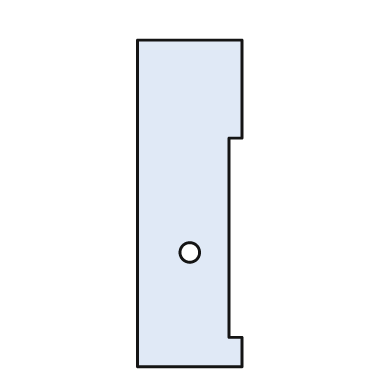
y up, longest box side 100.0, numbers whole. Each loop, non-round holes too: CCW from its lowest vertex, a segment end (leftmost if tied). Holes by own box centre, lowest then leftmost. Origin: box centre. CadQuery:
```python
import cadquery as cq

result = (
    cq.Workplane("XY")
    .moveTo(-16.0, -50.0)
    .lineTo(16.0, -50.0)
    .lineTo(16.0, -41.0)
    .lineTo(12.0, -41.0)
    .lineTo(12.0, 20.0)
    .lineTo(16.0, 20.0)
    .lineTo(16.0, 50.0)
    .lineTo(-16.0, 50.0)
    .close()
    .moveTo(0.0, -15.0)
    .circle(3.0)
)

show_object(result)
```